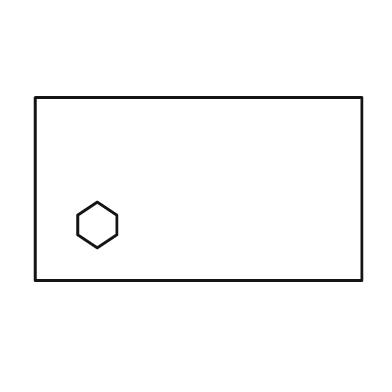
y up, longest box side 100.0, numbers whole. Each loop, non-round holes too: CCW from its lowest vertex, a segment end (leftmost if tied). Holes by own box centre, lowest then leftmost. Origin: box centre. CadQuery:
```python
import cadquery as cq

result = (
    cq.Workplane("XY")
    .moveTo(-50.0, -28.0)
    .lineTo(50.0, -28.0)
    .lineTo(50.0, 28.0)
    .lineTo(-50.0, 28.0)
    .close()
    .moveTo(-31.0, -18.0)
    .lineTo(-25.0, -14.0)
    .lineTo(-25.0, -8.0)
    .lineTo(-31.0, -4.0)
    .lineTo(-37.0, -8.0)
    .lineTo(-37.0, -14.0)
    .close()
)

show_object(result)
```